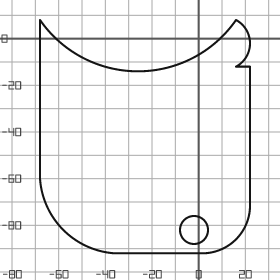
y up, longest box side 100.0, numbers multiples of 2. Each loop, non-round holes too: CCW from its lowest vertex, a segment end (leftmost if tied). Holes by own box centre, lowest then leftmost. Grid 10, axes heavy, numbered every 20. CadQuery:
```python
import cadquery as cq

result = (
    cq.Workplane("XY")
    .moveTo(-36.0, -92.0)
    .lineTo(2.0, -92.0)
    .threePointArc((16.0, -86.0), (22.0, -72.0))
    .lineTo(22.0, -12.0)
    .lineTo(16.0, -12.0)
    .threePointArc((22.0, -2.0), (16.0, 8.0))
    .threePointArc((-26.0, -14.0), (-68.0, 8.0))
    .lineTo(-68.0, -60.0)
    .threePointArc((-58.0, -82.0), (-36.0, -92.0))
    .close()
    .moveTo(-2.0, -82.0)
    .circle(6.0)
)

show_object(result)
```